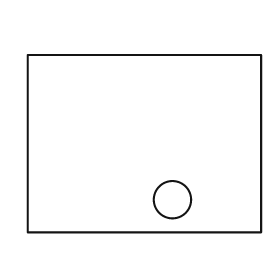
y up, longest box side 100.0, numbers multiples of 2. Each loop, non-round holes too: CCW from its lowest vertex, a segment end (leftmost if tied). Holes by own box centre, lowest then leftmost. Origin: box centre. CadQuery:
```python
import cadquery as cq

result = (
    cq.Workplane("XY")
    .moveTo(-50.0, -38.0)
    .lineTo(50.0, -38.0)
    .lineTo(50.0, 38.0)
    .lineTo(-50.0, 38.0)
    .close()
    .moveTo(12.0, -24.0)
    .circle(8.0)
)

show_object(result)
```